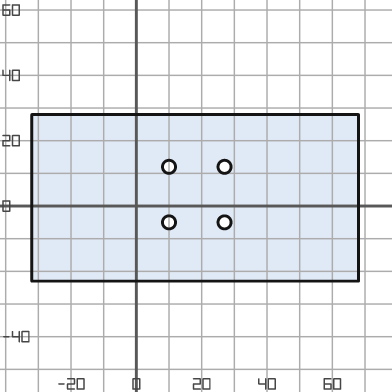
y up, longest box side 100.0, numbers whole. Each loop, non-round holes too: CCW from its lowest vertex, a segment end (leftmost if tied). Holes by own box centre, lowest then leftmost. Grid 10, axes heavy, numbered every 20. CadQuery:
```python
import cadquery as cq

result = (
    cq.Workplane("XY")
    .moveTo(-32.0, -23.0)
    .lineTo(68.0, -23.0)
    .lineTo(68.0, 28.0)
    .lineTo(-32.0, 28.0)
    .close()
    .moveTo(10.0, -5.0)
    .circle(2.0)
    .moveTo(27.0, -5.0)
    .circle(2.0)
    .moveTo(10.0, 12.0)
    .circle(2.0)
    .moveTo(27.0, 12.0)
    .circle(2.0)
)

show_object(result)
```